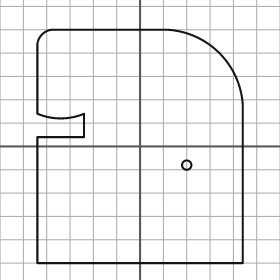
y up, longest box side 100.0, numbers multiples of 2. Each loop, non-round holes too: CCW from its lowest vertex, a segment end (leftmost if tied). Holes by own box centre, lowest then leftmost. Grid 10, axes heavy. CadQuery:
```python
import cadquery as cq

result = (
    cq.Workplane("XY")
    .moveTo(-44.0, -50.0)
    .lineTo(44.0, -50.0)
    .lineTo(44.0, 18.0)
    .threePointArc((34.0, 40.0), (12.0, 50.0))
    .lineTo(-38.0, 50.0)
    .threePointArc((-42.0, 48.0), (-44.0, 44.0))
    .lineTo(-44.0, 14.0)
    .threePointArc((-34.0, 12.0), (-24.0, 14.0))
    .lineTo(-24.0, 4.0)
    .lineTo(-44.0, 4.0)
    .close()
    .moveTo(20.0, -8.0)
    .circle(2.0)
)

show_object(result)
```